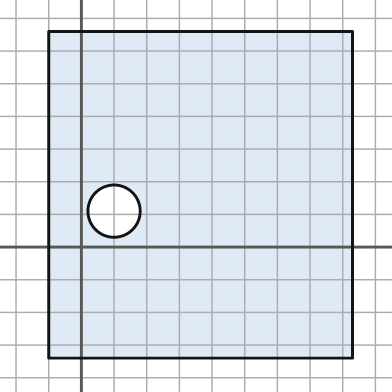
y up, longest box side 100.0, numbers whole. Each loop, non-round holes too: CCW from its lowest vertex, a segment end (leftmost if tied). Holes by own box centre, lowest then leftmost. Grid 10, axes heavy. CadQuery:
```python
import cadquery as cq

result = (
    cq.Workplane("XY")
    .moveTo(-10.0, -34.0)
    .lineTo(83.0, -34.0)
    .lineTo(83.0, 66.0)
    .lineTo(-10.0, 66.0)
    .close()
    .moveTo(10.0, 11.0)
    .circle(8.0)
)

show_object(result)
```